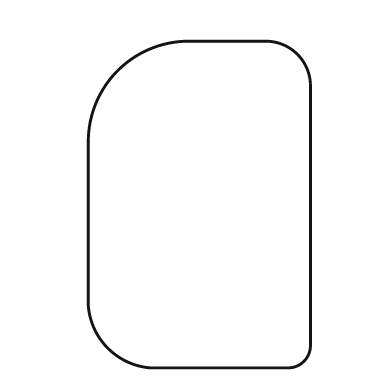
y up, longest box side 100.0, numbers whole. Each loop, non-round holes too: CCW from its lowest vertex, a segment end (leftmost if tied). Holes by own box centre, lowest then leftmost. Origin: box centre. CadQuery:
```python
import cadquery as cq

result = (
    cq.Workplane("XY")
    .moveTo(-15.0, -50.0)
    .lineTo(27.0, -50.0)
    .threePointArc((32.0, -48.0), (34.0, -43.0))
    .lineTo(34.0, 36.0)
    .threePointArc((30.0, 46.0), (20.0, 50.0))
    .lineTo(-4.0, 50.0)
    .threePointArc((-25.0, 41.0), (-34.0, 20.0))
    .lineTo(-34.0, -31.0)
    .threePointArc((-28.0, -44.0), (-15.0, -50.0))
    .close()
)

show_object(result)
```